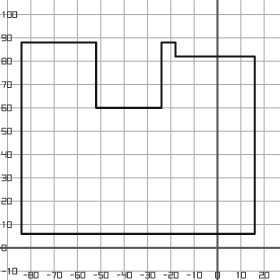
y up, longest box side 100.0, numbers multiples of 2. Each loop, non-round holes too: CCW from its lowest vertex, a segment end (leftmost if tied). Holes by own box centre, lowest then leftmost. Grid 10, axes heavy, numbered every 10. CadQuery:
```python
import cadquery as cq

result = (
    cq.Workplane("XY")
    .moveTo(-84.0, 6.0)
    .lineTo(16.0, 6.0)
    .lineTo(16.0, 82.0)
    .lineTo(-18.0, 82.0)
    .lineTo(-18.0, 88.0)
    .lineTo(-24.0, 88.0)
    .lineTo(-24.0, 60.0)
    .lineTo(-52.0, 60.0)
    .lineTo(-52.0, 88.0)
    .lineTo(-84.0, 88.0)
    .close()
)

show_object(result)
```